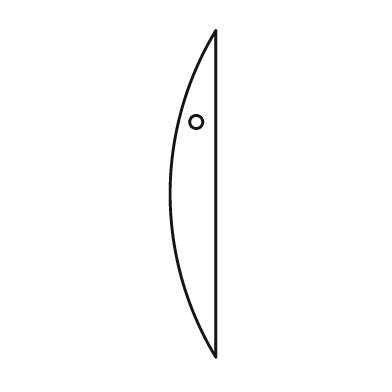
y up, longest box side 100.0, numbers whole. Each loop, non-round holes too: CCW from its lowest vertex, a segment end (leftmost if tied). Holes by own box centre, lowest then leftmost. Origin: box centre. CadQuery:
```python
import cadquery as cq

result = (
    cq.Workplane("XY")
    .moveTo(7.0, -50.0)
    .lineTo(7.0, 50.0)
    .threePointArc((-7.0, 0.0), (7.0, -50.0))
    .close()
    .moveTo(1.0, 22.0)
    .circle(2.0)
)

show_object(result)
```